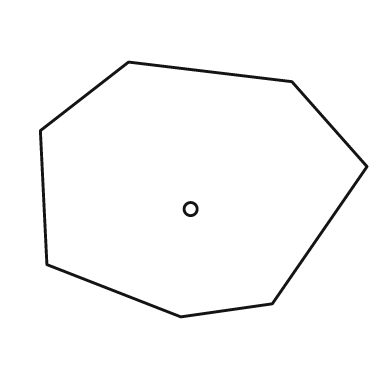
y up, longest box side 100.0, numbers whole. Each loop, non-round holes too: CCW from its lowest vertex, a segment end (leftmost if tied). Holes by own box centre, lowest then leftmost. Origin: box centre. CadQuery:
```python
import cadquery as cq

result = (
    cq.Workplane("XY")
    .moveTo(-7.0, -39.0)
    .lineTo(21.0, -35.0)
    .lineTo(50.0, 7.0)
    .lineTo(27.0, 33.0)
    .lineTo(-23.0, 39.0)
    .lineTo(-50.0, 18.0)
    .lineTo(-48.0, -23.0)
    .close()
    .moveTo(-4.0, -6.0)
    .circle(2.0)
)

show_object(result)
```